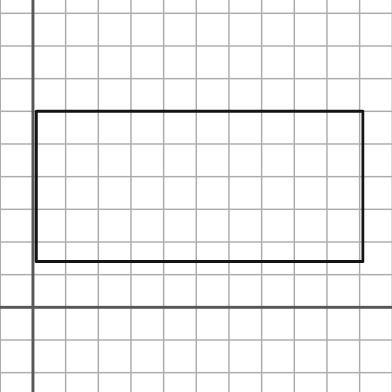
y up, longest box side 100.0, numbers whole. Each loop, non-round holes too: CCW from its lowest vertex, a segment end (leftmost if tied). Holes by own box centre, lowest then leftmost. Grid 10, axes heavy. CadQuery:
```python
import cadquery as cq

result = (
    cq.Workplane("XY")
    .moveTo(1.0, 14.0)
    .lineTo(101.0, 14.0)
    .lineTo(101.0, 60.0)
    .lineTo(1.0, 60.0)
    .close()
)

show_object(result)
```